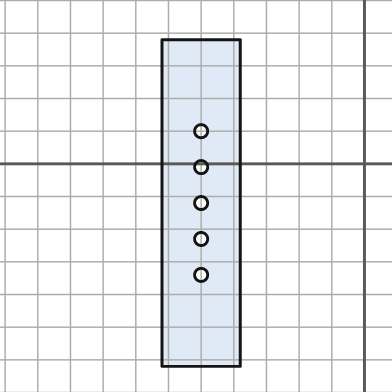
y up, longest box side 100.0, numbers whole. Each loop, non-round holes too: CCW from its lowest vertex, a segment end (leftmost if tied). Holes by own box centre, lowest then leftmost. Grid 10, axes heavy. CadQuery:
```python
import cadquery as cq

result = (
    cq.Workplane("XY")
    .moveTo(-62.0, -62.0)
    .lineTo(-38.0, -62.0)
    .lineTo(-38.0, 38.0)
    .lineTo(-62.0, 38.0)
    .close()
    .moveTo(-50.0, -34.0)
    .circle(2.0)
    .moveTo(-50.0, -23.0)
    .circle(2.0)
    .moveTo(-50.0, -12.0)
    .circle(2.0)
    .moveTo(-50.0, -1.0)
    .circle(2.0)
    .moveTo(-50.0, 10.0)
    .circle(2.0)
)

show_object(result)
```